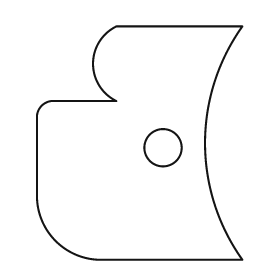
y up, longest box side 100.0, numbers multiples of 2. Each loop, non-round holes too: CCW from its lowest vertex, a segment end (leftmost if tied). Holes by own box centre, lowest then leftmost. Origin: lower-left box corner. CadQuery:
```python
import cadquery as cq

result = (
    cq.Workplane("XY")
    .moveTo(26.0, 0.0)
    .lineTo(88.0, 0.0)
    .threePointArc((72.0, 50.0), (88.0, 100.0))
    .lineTo(34.0, 100.0)
    .threePointArc((24.0, 84.0), (34.0, 68.0))
    .lineTo(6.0, 68.0)
    .threePointArc((2.0, 66.0), (0.0, 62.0))
    .lineTo(0.0, 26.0)
    .threePointArc((8.0, 8.0), (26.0, 0.0))
    .close()
    .moveTo(54.0, 48.0)
    .circle(8.0)
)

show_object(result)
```